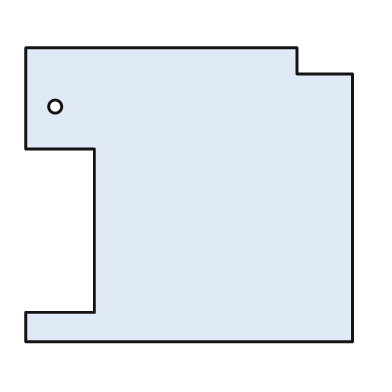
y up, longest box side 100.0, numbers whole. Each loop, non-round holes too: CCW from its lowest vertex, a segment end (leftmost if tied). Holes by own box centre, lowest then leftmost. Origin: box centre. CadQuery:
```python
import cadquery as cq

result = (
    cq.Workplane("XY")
    .moveTo(-50.0, -45.0)
    .lineTo(50.0, -45.0)
    .lineTo(50.0, 37.0)
    .lineTo(33.0, 37.0)
    .lineTo(33.0, 45.0)
    .lineTo(-50.0, 45.0)
    .lineTo(-50.0, 14.0)
    .lineTo(-29.0, 14.0)
    .lineTo(-29.0, -36.0)
    .lineTo(-50.0, -36.0)
    .close()
    .moveTo(-41.0, 27.0)
    .circle(2.0)
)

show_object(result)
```